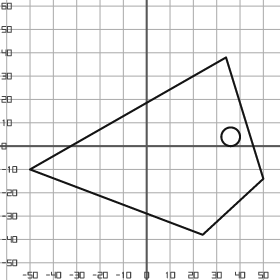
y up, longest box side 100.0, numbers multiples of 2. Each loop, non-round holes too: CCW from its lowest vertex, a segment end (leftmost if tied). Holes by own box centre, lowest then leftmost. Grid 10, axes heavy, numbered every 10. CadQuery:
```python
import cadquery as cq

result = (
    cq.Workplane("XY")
    .moveTo(24.0, -38.0)
    .lineTo(50.0, -14.0)
    .lineTo(34.0, 38.0)
    .lineTo(-50.0, -10.0)
    .close()
    .moveTo(36.0, 4.0)
    .circle(4.0)
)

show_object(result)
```